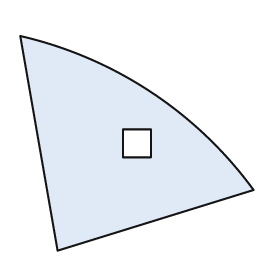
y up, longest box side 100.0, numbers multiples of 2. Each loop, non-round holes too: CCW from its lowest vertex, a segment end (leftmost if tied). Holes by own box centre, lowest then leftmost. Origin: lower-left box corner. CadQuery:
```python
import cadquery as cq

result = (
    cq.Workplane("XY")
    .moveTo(16.0, 0.0)
    .lineTo(100.0, 26.0)
    .threePointArc((56.0, 68.0), (0.0, 92.0))
    .close()
    .moveTo(44.0, 40.0)
    .lineTo(56.0, 40.0)
    .lineTo(56.0, 52.0)
    .lineTo(44.0, 52.0)
    .close()
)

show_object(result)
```